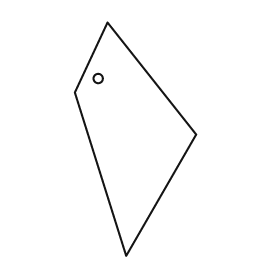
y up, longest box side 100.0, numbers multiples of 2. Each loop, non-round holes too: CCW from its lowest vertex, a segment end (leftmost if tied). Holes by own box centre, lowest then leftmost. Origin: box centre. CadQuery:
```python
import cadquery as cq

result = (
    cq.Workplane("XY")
    .moveTo(-4.0, -50.0)
    .lineTo(26.0, 2.0)
    .lineTo(-12.0, 50.0)
    .lineTo(-26.0, 20.0)
    .close()
    .moveTo(-16.0, 26.0)
    .circle(2.0)
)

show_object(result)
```